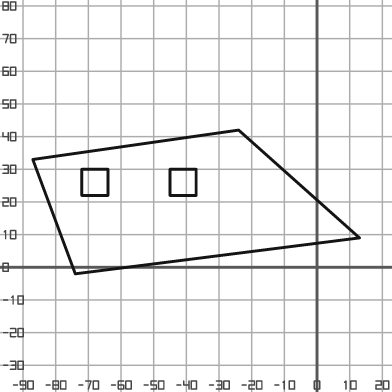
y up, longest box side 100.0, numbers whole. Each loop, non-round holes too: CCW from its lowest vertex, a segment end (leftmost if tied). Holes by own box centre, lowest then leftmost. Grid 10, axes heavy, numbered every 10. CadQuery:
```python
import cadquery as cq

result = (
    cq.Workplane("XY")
    .moveTo(-74.0, -2.0)
    .lineTo(13.0, 9.0)
    .lineTo(-24.0, 42.0)
    .lineTo(-87.0, 33.0)
    .close()
    .moveTo(-72.0, 22.0)
    .lineTo(-64.0, 22.0)
    .lineTo(-64.0, 30.0)
    .lineTo(-72.0, 30.0)
    .close()
    .moveTo(-45.0, 22.0)
    .lineTo(-37.0, 22.0)
    .lineTo(-37.0, 30.0)
    .lineTo(-45.0, 30.0)
    .close()
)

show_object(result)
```